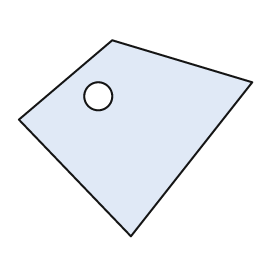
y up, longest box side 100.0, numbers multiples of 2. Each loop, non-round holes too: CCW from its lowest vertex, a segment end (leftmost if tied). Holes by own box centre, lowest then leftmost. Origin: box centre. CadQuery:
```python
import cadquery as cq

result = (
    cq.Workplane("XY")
    .moveTo(-2.0, -42.0)
    .lineTo(50.0, 24.0)
    .lineTo(-10.0, 42.0)
    .lineTo(-50.0, 8.0)
    .close()
    .moveTo(-16.0, 18.0)
    .circle(6.0)
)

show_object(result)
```